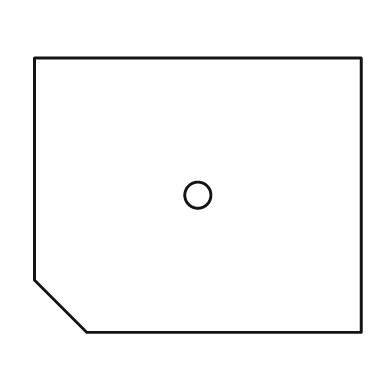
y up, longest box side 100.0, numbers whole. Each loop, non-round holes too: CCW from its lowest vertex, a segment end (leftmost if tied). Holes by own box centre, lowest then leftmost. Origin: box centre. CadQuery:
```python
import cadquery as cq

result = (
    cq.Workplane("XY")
    .moveTo(-34.0, -42.0)
    .lineTo(50.0, -42.0)
    .lineTo(50.0, 42.0)
    .lineTo(-50.0, 42.0)
    .lineTo(-50.0, -26.0)
    .close()
    .moveTo(0.0, 0.0)
    .circle(4.0)
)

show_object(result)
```